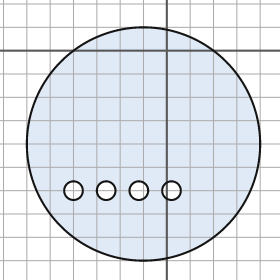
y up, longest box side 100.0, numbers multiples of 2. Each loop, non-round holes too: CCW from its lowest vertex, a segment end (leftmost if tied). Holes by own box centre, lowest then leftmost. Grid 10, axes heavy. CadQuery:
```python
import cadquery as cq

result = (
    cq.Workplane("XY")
    .moveTo(-10.0, -40.0)
    .circle(50.0)
    .moveTo(-40.0, -60.0)
    .circle(4.0)
    .moveTo(-26.0, -60.0)
    .circle(4.0)
    .moveTo(-12.0, -60.0)
    .circle(4.0)
    .moveTo(2.0, -60.0)
    .circle(4.0)
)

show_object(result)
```